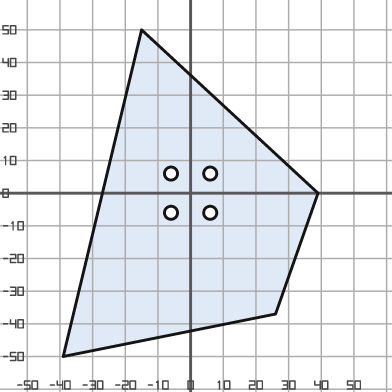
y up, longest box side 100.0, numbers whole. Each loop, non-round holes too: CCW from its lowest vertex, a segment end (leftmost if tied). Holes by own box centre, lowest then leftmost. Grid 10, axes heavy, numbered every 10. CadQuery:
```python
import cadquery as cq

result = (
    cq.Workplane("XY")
    .moveTo(-39.0, -50.0)
    .lineTo(26.0, -37.0)
    .lineTo(39.0, 0.0)
    .lineTo(-15.0, 50.0)
    .close()
    .moveTo(-6.0, -6.0)
    .circle(2.0)
    .moveTo(6.0, -6.0)
    .circle(2.0)
    .moveTo(-6.0, 6.0)
    .circle(2.0)
    .moveTo(6.0, 6.0)
    .circle(2.0)
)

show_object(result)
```